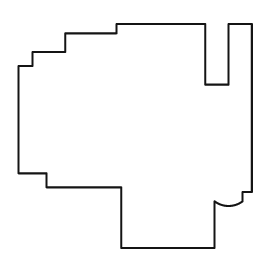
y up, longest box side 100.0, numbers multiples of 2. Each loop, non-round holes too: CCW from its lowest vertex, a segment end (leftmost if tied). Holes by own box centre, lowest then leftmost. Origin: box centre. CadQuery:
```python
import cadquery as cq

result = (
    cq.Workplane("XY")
    .moveTo(-6.0, -48.0)
    .lineTo(34.0, -48.0)
    .lineTo(34.0, -28.0)
    .threePointArc((40.0, -30.0), (46.0, -28.0))
    .lineTo(46.0, -24.0)
    .lineTo(50.0, -24.0)
    .lineTo(50.0, 48.0)
    .lineTo(40.0, 48.0)
    .lineTo(40.0, 22.0)
    .lineTo(30.0, 22.0)
    .lineTo(30.0, 48.0)
    .lineTo(-8.0, 48.0)
    .lineTo(-8.0, 44.0)
    .lineTo(-30.0, 44.0)
    .lineTo(-30.0, 36.0)
    .lineTo(-44.0, 36.0)
    .lineTo(-44.0, 30.0)
    .lineTo(-50.0, 30.0)
    .lineTo(-50.0, -16.0)
    .lineTo(-38.0, -16.0)
    .lineTo(-38.0, -22.0)
    .lineTo(-6.0, -22.0)
    .close()
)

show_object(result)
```